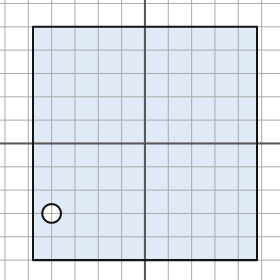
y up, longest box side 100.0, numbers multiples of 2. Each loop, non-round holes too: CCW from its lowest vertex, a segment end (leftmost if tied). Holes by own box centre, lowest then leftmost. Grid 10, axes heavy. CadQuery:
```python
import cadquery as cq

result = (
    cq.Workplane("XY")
    .moveTo(-48.0, -50.0)
    .lineTo(48.0, -50.0)
    .lineTo(48.0, 50.0)
    .lineTo(-48.0, 50.0)
    .close()
    .moveTo(-40.0, -30.0)
    .circle(4.0)
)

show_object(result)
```